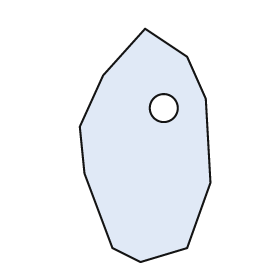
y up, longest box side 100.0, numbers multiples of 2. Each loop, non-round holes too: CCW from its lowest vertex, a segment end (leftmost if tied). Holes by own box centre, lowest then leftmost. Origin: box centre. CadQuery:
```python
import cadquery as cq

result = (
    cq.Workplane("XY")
    .moveTo(-2.0, -50.0)
    .lineTo(18.0, -44.0)
    .lineTo(28.0, -16.0)
    .lineTo(26.0, 20.0)
    .lineTo(18.0, 38.0)
    .lineTo(0.0, 50.0)
    .lineTo(-18.0, 30.0)
    .lineTo(-28.0, 8.0)
    .lineTo(-26.0, -12.0)
    .lineTo(-14.0, -44.0)
    .close()
    .moveTo(8.0, 16.0)
    .circle(6.0)
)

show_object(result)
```